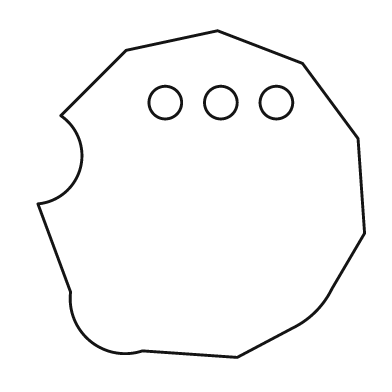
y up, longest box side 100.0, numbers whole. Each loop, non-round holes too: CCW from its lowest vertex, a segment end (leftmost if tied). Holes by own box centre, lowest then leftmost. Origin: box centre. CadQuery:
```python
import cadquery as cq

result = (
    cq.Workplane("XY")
    .moveTo(11.0, -50.0)
    .lineTo(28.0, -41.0)
    .threePointArc((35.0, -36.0), (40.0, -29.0))
    .lineTo(50.0, -12.0)
    .lineTo(48.0, 17.0)
    .lineTo(31.0, 40.0)
    .lineTo(5.0, 50.0)
    .lineTo(-23.0, 44.0)
    .lineTo(-43.0, 24.0)
    .threePointArc((-37.0, 8.0), (-50.0, -3.0))
    .lineTo(-40.0, -30.0)
    .threePointArc((-34.0, -45.0), (-18.0, -48.0))
    .close()
    .moveTo(-11.0, 28.0)
    .circle(5.0)
    .moveTo(6.0, 28.0)
    .circle(5.0)
    .moveTo(23.0, 28.0)
    .circle(5.0)
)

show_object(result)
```